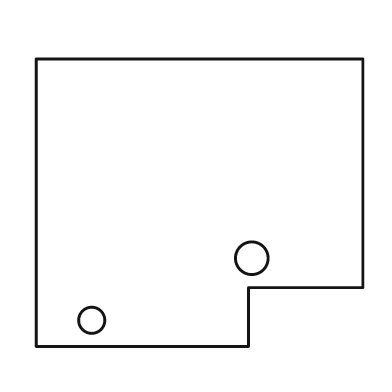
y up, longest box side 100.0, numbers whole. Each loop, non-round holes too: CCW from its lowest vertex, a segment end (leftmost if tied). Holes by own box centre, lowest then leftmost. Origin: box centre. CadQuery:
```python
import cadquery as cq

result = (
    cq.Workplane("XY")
    .moveTo(-50.0, -44.0)
    .lineTo(15.0, -44.0)
    .lineTo(15.0, -26.0)
    .lineTo(50.0, -26.0)
    .lineTo(50.0, 44.0)
    .lineTo(-50.0, 44.0)
    .close()
    .moveTo(-33.0, -36.0)
    .circle(4.0)
    .moveTo(16.0, -17.0)
    .circle(5.0)
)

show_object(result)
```